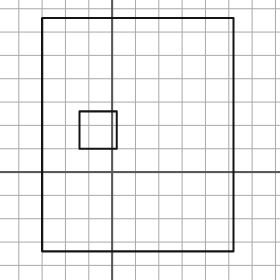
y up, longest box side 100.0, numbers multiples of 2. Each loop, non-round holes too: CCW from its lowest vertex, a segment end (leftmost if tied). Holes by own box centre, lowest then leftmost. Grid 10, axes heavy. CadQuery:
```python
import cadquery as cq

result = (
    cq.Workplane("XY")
    .moveTo(-30.0, -34.0)
    .lineTo(52.0, -34.0)
    .lineTo(52.0, 66.0)
    .lineTo(-30.0, 66.0)
    .close()
    .moveTo(-14.0, 10.0)
    .lineTo(2.0, 10.0)
    .lineTo(2.0, 26.0)
    .lineTo(-14.0, 26.0)
    .close()
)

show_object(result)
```